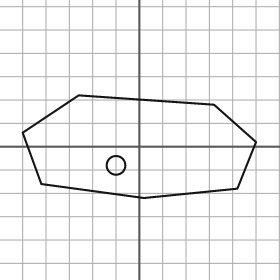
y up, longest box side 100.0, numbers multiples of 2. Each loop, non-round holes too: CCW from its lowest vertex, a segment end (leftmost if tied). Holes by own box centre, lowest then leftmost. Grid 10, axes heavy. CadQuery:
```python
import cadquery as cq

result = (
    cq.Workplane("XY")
    .moveTo(2.0, -22.0)
    .lineTo(42.0, -18.0)
    .lineTo(50.0, 2.0)
    .lineTo(32.0, 18.0)
    .lineTo(-26.0, 22.0)
    .lineTo(-50.0, 6.0)
    .lineTo(-42.0, -16.0)
    .close()
    .moveTo(-10.0, -8.0)
    .circle(4.0)
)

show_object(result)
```